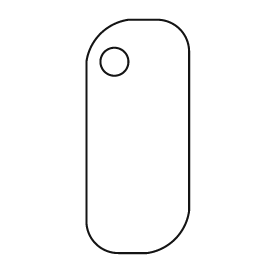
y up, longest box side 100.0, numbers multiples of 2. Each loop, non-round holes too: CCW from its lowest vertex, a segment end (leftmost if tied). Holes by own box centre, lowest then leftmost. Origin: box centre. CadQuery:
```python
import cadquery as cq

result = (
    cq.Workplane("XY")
    .moveTo(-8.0, -50.0)
    .lineTo(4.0, -50.0)
    .threePointArc((16.0, -44.0), (22.0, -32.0))
    .lineTo(22.0, 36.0)
    .threePointArc((18.0, 46.0), (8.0, 50.0))
    .lineTo(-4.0, 50.0)
    .threePointArc((-16.0, 44.0), (-22.0, 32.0))
    .lineTo(-22.0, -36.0)
    .threePointArc((-18.0, -46.0), (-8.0, -50.0))
    .close()
    .moveTo(-10.0, 32.0)
    .circle(6.0)
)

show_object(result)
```